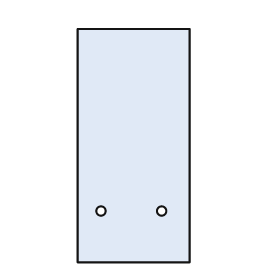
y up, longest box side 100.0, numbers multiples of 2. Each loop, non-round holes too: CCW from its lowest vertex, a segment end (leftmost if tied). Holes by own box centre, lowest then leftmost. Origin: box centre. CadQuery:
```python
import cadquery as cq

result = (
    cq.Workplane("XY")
    .moveTo(-24.0, -50.0)
    .lineTo(24.0, -50.0)
    .lineTo(24.0, 50.0)
    .lineTo(-24.0, 50.0)
    .close()
    .moveTo(-14.0, -28.0)
    .circle(2.0)
    .moveTo(12.0, -28.0)
    .circle(2.0)
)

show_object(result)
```